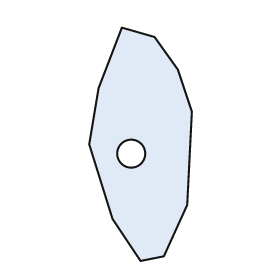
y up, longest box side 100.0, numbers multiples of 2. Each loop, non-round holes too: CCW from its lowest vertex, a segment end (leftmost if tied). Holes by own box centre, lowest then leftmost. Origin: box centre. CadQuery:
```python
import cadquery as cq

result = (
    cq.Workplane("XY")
    .moveTo(0.0, -50.0)
    .lineTo(10.0, -48.0)
    .lineTo(20.0, -26.0)
    .lineTo(22.0, 14.0)
    .lineTo(16.0, 32.0)
    .lineTo(6.0, 46.0)
    .lineTo(-8.0, 50.0)
    .lineTo(-18.0, 24.0)
    .lineTo(-22.0, 0.0)
    .lineTo(-12.0, -32.0)
    .close()
    .moveTo(-4.0, -4.0)
    .circle(6.0)
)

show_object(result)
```